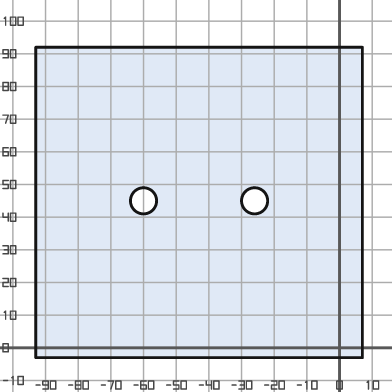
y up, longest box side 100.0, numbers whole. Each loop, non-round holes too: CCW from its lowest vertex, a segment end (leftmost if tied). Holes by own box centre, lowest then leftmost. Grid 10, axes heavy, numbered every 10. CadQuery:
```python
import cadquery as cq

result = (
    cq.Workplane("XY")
    .moveTo(-93.0, -3.0)
    .lineTo(7.0, -3.0)
    .lineTo(7.0, 92.0)
    .lineTo(-93.0, 92.0)
    .close()
    .moveTo(-60.0, 45.0)
    .circle(4.0)
    .moveTo(-26.0, 45.0)
    .circle(4.0)
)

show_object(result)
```